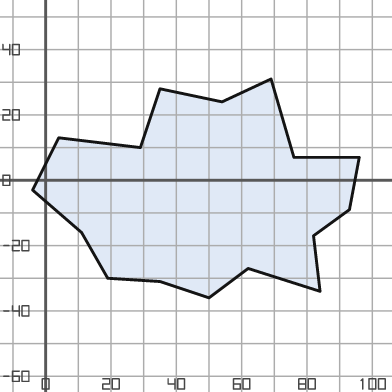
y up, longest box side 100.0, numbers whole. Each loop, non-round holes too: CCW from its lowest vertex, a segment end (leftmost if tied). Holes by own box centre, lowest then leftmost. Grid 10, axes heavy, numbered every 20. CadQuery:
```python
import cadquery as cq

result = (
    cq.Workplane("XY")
    .moveTo(50.0, -36.0)
    .lineTo(62.0, -27.0)
    .lineTo(84.0, -34.0)
    .lineTo(82.0, -17.0)
    .lineTo(93.0, -9.0)
    .lineTo(96.0, 7.0)
    .lineTo(76.0, 7.0)
    .lineTo(69.0, 31.0)
    .lineTo(54.0, 24.0)
    .lineTo(35.0, 28.0)
    .lineTo(29.0, 10.0)
    .lineTo(4.0, 13.0)
    .lineTo(-4.0, -3.0)
    .lineTo(11.0, -16.0)
    .lineTo(19.0, -30.0)
    .lineTo(35.0, -31.0)
    .close()
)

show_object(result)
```